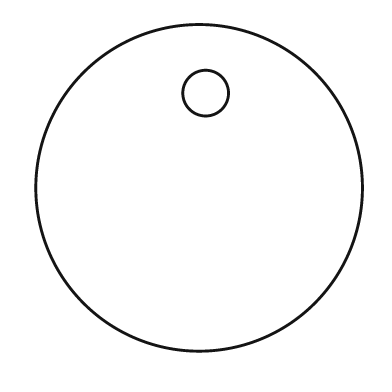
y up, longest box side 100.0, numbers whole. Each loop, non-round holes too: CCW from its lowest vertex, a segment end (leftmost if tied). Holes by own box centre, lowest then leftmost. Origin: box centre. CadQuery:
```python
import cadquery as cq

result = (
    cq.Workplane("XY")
    .moveTo(0.0, 0.0)
    .circle(50.0)
    .moveTo(2.0, 29.0)
    .circle(7.0)
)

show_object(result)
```